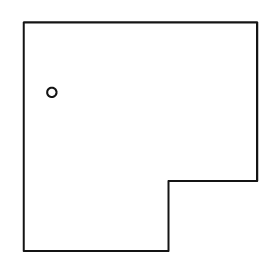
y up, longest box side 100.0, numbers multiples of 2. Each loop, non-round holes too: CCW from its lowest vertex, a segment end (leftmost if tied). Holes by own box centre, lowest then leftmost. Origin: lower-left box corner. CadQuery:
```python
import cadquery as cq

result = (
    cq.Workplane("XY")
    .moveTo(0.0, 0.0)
    .lineTo(62.0, 0.0)
    .lineTo(62.0, 30.0)
    .lineTo(100.0, 30.0)
    .lineTo(100.0, 98.0)
    .lineTo(0.0, 98.0)
    .close()
    .moveTo(12.0, 68.0)
    .circle(2.0)
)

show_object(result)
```